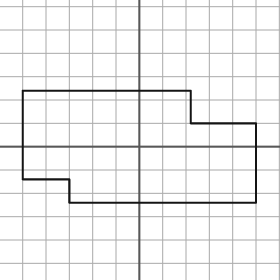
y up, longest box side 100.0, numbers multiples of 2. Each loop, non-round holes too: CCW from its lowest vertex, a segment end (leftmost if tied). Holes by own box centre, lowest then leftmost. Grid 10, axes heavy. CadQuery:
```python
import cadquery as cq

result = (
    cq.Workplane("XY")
    .moveTo(-30.0, -24.0)
    .lineTo(50.0, -24.0)
    .lineTo(50.0, 10.0)
    .lineTo(22.0, 10.0)
    .lineTo(22.0, 24.0)
    .lineTo(-50.0, 24.0)
    .lineTo(-50.0, -14.0)
    .lineTo(-30.0, -14.0)
    .close()
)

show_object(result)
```